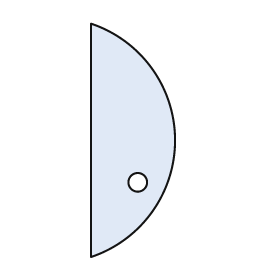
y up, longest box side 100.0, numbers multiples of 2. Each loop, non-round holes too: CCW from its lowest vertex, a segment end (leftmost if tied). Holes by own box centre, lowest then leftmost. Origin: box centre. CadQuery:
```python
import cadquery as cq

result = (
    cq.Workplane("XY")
    .moveTo(-18.0, -50.0)
    .threePointArc((18.0, 0.0), (-18.0, 50.0))
    .close()
    .moveTo(2.0, -18.0)
    .circle(4.0)
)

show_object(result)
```